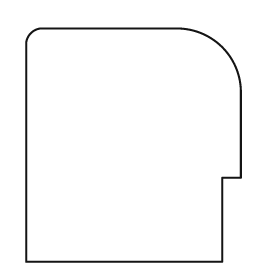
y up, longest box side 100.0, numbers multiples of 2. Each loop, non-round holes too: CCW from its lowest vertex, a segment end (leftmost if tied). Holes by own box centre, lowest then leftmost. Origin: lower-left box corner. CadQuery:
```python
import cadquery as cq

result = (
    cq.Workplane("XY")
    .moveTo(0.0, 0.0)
    .lineTo(84.0, 0.0)
    .lineTo(84.0, 36.0)
    .lineTo(92.0, 36.0)
    .lineTo(92.0, 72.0)
    .threePointArc((84.0, 92.0), (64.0, 100.0))
    .lineTo(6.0, 100.0)
    .threePointArc((2.0, 98.0), (0.0, 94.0))
    .close()
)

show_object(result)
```